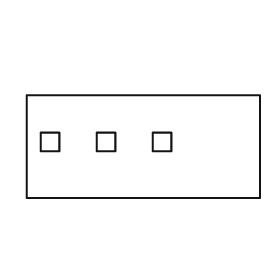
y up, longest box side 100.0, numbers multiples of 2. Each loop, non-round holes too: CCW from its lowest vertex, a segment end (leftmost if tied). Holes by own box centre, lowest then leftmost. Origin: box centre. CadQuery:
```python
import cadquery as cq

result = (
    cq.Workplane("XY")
    .moveTo(-50.0, -22.0)
    .lineTo(50.0, -22.0)
    .lineTo(50.0, 22.0)
    .lineTo(-50.0, 22.0)
    .close()
    .moveTo(-44.0, -2.0)
    .lineTo(-36.0, -2.0)
    .lineTo(-36.0, 6.0)
    .lineTo(-44.0, 6.0)
    .close()
    .moveTo(-20.0, -2.0)
    .lineTo(-12.0, -2.0)
    .lineTo(-12.0, 6.0)
    .lineTo(-20.0, 6.0)
    .close()
    .moveTo(4.0, -2.0)
    .lineTo(12.0, -2.0)
    .lineTo(12.0, 6.0)
    .lineTo(4.0, 6.0)
    .close()
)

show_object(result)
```